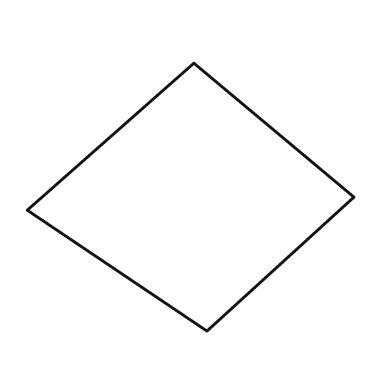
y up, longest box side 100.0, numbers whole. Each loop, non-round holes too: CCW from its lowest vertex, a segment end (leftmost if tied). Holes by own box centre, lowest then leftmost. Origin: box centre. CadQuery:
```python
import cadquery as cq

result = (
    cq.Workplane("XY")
    .moveTo(5.0, -41.0)
    .lineTo(50.0, 0.0)
    .lineTo(1.0, 41.0)
    .lineTo(-50.0, -4.0)
    .close()
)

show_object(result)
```